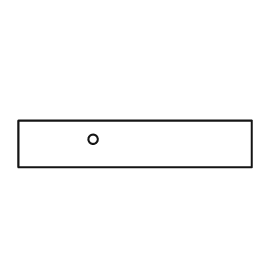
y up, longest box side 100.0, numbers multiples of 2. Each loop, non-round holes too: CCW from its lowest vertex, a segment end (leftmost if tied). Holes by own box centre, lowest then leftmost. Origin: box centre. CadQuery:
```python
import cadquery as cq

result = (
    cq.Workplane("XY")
    .moveTo(-50.0, -10.0)
    .lineTo(50.0, -10.0)
    .lineTo(50.0, 10.0)
    .lineTo(-50.0, 10.0)
    .close()
    .moveTo(-18.0, 2.0)
    .circle(2.0)
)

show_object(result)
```